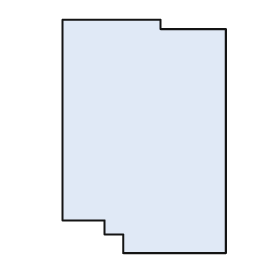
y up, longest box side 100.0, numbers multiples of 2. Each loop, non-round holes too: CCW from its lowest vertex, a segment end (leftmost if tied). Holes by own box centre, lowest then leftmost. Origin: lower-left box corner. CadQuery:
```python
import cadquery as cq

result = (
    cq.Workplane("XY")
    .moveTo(26.0, 0.0)
    .lineTo(70.0, 0.0)
    .lineTo(70.0, 96.0)
    .lineTo(42.0, 96.0)
    .lineTo(42.0, 100.0)
    .lineTo(0.0, 100.0)
    .lineTo(0.0, 14.0)
    .lineTo(18.0, 14.0)
    .lineTo(18.0, 8.0)
    .lineTo(26.0, 8.0)
    .close()
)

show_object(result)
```